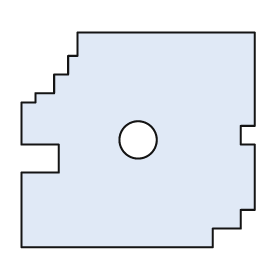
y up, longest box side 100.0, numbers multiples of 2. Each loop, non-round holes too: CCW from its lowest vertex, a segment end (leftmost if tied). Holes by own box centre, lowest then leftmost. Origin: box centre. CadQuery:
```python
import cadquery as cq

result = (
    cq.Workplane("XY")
    .moveTo(-50.0, -46.0)
    .lineTo(32.0, -46.0)
    .lineTo(32.0, -38.0)
    .lineTo(44.0, -38.0)
    .lineTo(44.0, -30.0)
    .lineTo(50.0, -30.0)
    .lineTo(50.0, -2.0)
    .lineTo(44.0, -2.0)
    .lineTo(44.0, 6.0)
    .lineTo(50.0, 6.0)
    .lineTo(50.0, 46.0)
    .lineTo(-26.0, 46.0)
    .lineTo(-26.0, 36.0)
    .lineTo(-30.0, 36.0)
    .lineTo(-30.0, 28.0)
    .lineTo(-36.0, 28.0)
    .lineTo(-36.0, 20.0)
    .lineTo(-44.0, 20.0)
    .lineTo(-44.0, 16.0)
    .lineTo(-50.0, 16.0)
    .lineTo(-50.0, -2.0)
    .lineTo(-34.0, -2.0)
    .lineTo(-34.0, -14.0)
    .lineTo(-50.0, -14.0)
    .close()
    .moveTo(0.0, 0.0)
    .circle(8.0)
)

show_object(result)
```